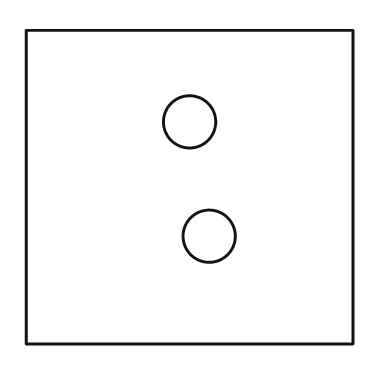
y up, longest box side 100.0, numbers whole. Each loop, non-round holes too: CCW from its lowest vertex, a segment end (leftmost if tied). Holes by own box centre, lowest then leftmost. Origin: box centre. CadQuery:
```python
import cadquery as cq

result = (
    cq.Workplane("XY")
    .moveTo(-50.0, -48.0)
    .lineTo(50.0, -48.0)
    .lineTo(50.0, 48.0)
    .lineTo(-50.0, 48.0)
    .close()
    .moveTo(6.0, -15.0)
    .circle(8.0)
    .moveTo(0.0, 20.0)
    .circle(8.0)
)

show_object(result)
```